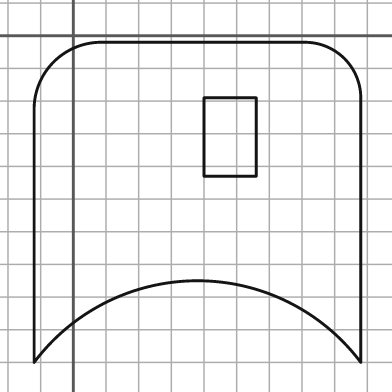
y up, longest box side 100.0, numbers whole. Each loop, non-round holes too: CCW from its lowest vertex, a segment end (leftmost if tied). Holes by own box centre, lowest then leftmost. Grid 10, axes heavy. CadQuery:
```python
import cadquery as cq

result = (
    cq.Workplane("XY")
    .moveTo(-12.0, -100.0)
    .threePointArc((38.0, -75.0), (88.0, -100.0))
    .lineTo(88.0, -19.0)
    .threePointArc((83.0, -7.0), (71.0, -2.0))
    .lineTo(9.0, -2.0)
    .threePointArc((-6.0, -8.0), (-12.0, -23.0))
    .close()
    .moveTo(40.0, -43.0)
    .lineTo(56.0, -43.0)
    .lineTo(56.0, -19.0)
    .lineTo(40.0, -19.0)
    .close()
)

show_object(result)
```